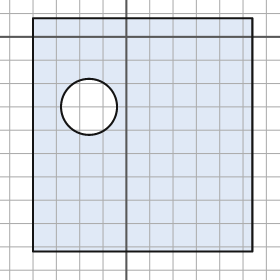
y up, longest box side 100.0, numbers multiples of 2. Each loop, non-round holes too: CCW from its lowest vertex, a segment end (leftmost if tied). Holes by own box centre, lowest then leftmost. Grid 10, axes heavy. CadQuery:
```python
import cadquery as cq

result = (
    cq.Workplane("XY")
    .moveTo(-40.0, -92.0)
    .lineTo(54.0, -92.0)
    .lineTo(54.0, 8.0)
    .lineTo(-40.0, 8.0)
    .close()
    .moveTo(-16.0, -30.0)
    .circle(12.0)
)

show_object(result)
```